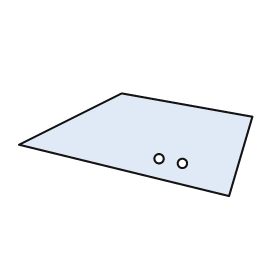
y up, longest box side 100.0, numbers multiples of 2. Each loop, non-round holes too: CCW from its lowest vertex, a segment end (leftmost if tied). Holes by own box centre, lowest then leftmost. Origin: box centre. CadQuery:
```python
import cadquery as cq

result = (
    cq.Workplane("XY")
    .moveTo(40.0, -22.0)
    .lineTo(50.0, 12.0)
    .lineTo(-6.0, 22.0)
    .lineTo(-50.0, 0.0)
    .close()
    .moveTo(20.0, -8.0)
    .circle(2.0)
    .moveTo(10.0, -6.0)
    .circle(2.0)
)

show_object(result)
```